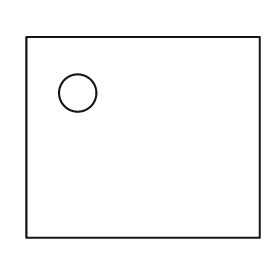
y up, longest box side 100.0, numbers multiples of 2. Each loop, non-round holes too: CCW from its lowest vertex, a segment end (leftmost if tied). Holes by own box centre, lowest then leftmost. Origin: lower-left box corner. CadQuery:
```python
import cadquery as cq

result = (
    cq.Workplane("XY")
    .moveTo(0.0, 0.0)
    .lineTo(100.0, 0.0)
    .lineTo(100.0, 86.0)
    .lineTo(0.0, 86.0)
    .close()
    .moveTo(22.0, 62.0)
    .circle(8.0)
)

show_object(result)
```